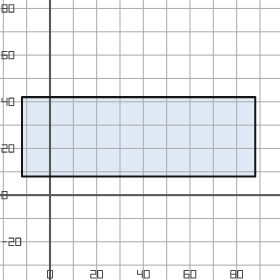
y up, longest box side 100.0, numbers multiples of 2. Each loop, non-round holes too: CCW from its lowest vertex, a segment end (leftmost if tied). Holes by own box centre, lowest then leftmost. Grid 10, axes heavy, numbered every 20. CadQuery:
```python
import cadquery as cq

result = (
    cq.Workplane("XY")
    .moveTo(-12.0, 8.0)
    .lineTo(88.0, 8.0)
    .lineTo(88.0, 42.0)
    .lineTo(-12.0, 42.0)
    .close()
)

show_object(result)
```